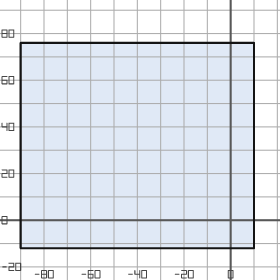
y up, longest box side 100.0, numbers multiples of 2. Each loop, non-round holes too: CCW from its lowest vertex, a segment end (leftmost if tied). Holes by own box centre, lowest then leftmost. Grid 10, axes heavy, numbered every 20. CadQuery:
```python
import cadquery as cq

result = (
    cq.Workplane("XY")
    .moveTo(-90.0, -12.0)
    .lineTo(10.0, -12.0)
    .lineTo(10.0, 76.0)
    .lineTo(-90.0, 76.0)
    .close()
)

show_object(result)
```